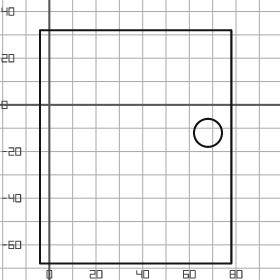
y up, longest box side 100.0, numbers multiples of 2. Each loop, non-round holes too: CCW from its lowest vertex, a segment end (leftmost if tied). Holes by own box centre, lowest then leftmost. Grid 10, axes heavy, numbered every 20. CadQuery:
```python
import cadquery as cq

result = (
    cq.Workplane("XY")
    .moveTo(-4.0, -68.0)
    .lineTo(78.0, -68.0)
    .lineTo(78.0, 32.0)
    .lineTo(-4.0, 32.0)
    .close()
    .moveTo(68.0, -12.0)
    .circle(6.0)
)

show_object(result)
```